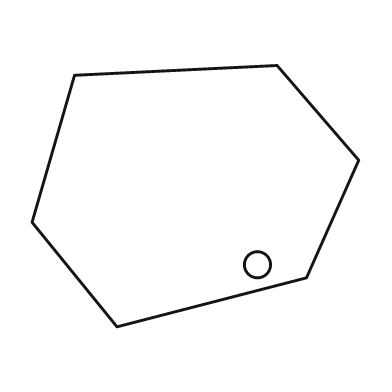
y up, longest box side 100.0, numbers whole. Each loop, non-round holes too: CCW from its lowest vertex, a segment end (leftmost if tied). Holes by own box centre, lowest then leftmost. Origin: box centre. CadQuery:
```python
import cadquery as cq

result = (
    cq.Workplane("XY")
    .moveTo(-24.0, -40.0)
    .lineTo(34.0, -25.0)
    .lineTo(50.0, 11.0)
    .lineTo(25.0, 40.0)
    .lineTo(-37.0, 37.0)
    .lineTo(-50.0, -8.0)
    .close()
    .moveTo(19.0, -21.0)
    .circle(4.0)
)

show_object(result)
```